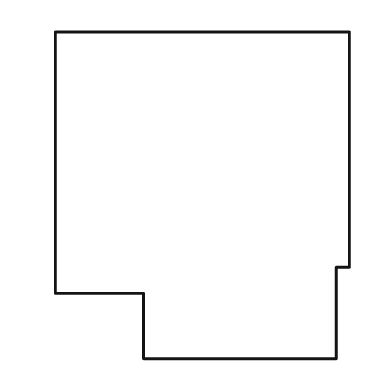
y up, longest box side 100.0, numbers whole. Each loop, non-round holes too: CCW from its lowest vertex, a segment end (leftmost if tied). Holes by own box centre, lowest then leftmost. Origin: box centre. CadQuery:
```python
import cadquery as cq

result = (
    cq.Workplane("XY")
    .moveTo(-18.0, -50.0)
    .lineTo(41.0, -50.0)
    .lineTo(41.0, -22.0)
    .lineTo(45.0, -22.0)
    .lineTo(45.0, 50.0)
    .lineTo(-45.0, 50.0)
    .lineTo(-45.0, -30.0)
    .lineTo(-18.0, -30.0)
    .close()
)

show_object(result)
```